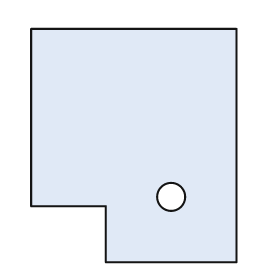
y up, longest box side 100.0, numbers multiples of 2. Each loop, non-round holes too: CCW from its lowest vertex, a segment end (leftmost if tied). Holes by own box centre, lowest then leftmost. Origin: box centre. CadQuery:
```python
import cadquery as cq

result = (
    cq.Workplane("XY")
    .moveTo(-12.0, -50.0)
    .lineTo(44.0, -50.0)
    .lineTo(44.0, 50.0)
    .lineTo(-44.0, 50.0)
    .lineTo(-44.0, -26.0)
    .lineTo(-12.0, -26.0)
    .close()
    .moveTo(16.0, -22.0)
    .circle(6.0)
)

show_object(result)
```